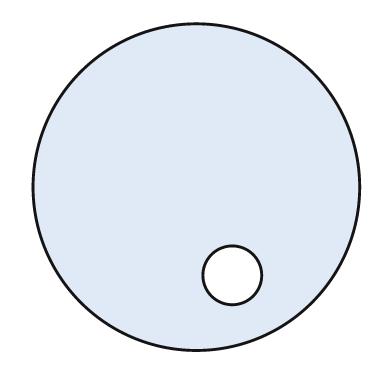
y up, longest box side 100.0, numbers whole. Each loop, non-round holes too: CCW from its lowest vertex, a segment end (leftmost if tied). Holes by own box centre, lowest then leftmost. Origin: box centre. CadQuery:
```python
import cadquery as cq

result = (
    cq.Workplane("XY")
    .moveTo(0.0, 0.0)
    .circle(50.0)
    .moveTo(11.0, -27.0)
    .circle(9.0)
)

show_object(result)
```